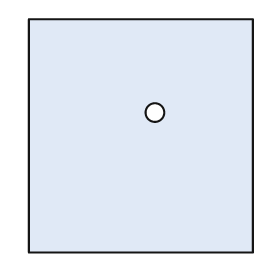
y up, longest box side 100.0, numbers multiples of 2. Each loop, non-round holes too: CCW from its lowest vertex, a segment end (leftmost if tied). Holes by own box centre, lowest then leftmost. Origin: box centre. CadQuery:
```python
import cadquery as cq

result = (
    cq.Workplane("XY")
    .moveTo(-48.0, -50.0)
    .lineTo(48.0, -50.0)
    .lineTo(48.0, 50.0)
    .lineTo(-48.0, 50.0)
    .close()
    .moveTo(6.0, 10.0)
    .circle(4.0)
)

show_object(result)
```